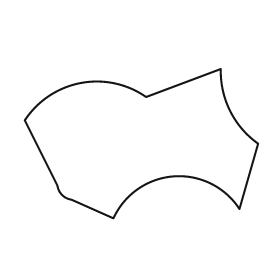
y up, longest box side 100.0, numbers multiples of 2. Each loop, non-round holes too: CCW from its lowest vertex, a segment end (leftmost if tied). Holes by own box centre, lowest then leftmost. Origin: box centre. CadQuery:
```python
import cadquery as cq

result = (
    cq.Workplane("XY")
    .moveTo(-12.0, -32.0)
    .threePointArc((14.0, -14.0), (42.0, -28.0))
    .lineTo(50.0, 0.0)
    .threePointArc((38.0, 14.0), (34.0, 32.0))
    .lineTo(2.0, 20.0)
    .threePointArc((-26.0, 26.0), (-50.0, 10.0))
    .lineTo(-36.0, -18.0)
    .threePointArc((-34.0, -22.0), (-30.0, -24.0))
    .close()
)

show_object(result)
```